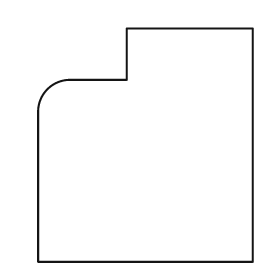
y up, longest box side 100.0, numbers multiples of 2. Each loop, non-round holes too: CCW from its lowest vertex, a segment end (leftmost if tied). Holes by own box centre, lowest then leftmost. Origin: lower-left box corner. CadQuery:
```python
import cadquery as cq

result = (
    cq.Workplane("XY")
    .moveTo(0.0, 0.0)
    .lineTo(92.0, 0.0)
    .lineTo(92.0, 100.0)
    .lineTo(38.0, 100.0)
    .lineTo(38.0, 78.0)
    .lineTo(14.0, 78.0)
    .threePointArc((4.0, 74.0), (0.0, 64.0))
    .close()
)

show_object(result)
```